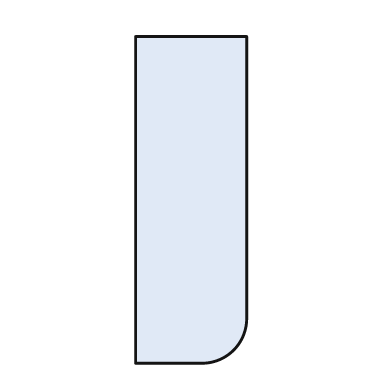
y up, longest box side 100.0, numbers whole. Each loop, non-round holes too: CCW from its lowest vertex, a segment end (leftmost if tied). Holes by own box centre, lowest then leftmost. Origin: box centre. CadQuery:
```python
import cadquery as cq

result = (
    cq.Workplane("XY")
    .moveTo(-17.0, -50.0)
    .lineTo(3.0, -50.0)
    .threePointArc((13.0, -46.0), (17.0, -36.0))
    .lineTo(17.0, 50.0)
    .lineTo(-17.0, 50.0)
    .close()
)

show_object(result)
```